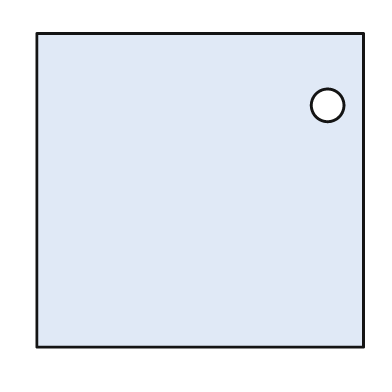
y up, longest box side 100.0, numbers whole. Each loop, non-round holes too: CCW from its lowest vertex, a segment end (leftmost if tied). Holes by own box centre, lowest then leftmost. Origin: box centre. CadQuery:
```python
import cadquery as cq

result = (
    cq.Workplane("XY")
    .moveTo(-50.0, -48.0)
    .lineTo(50.0, -48.0)
    .lineTo(50.0, 48.0)
    .lineTo(-50.0, 48.0)
    .close()
    .moveTo(39.0, 26.0)
    .circle(5.0)
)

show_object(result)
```